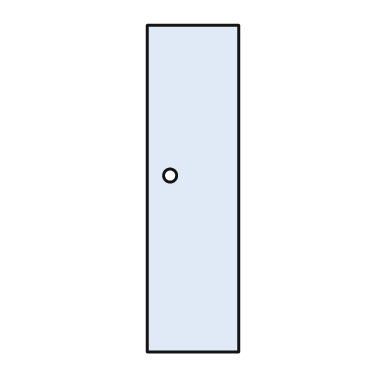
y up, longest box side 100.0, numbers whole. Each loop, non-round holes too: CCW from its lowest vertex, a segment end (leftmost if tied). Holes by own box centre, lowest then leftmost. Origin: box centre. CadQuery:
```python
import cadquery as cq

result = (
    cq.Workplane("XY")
    .moveTo(-14.0, -50.0)
    .lineTo(14.0, -50.0)
    .lineTo(14.0, 50.0)
    .lineTo(-14.0, 50.0)
    .close()
    .moveTo(-7.0, 4.0)
    .circle(2.0)
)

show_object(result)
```